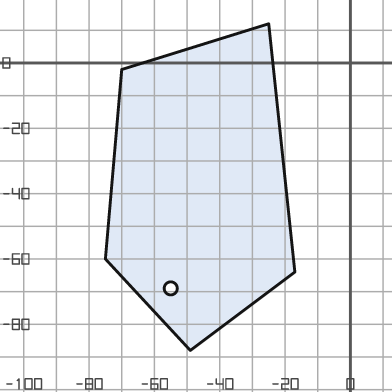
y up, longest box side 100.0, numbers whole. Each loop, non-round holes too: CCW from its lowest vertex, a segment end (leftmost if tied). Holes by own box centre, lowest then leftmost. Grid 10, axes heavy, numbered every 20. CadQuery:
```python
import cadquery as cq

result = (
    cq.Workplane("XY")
    .moveTo(-49.0, -88.0)
    .lineTo(-17.0, -64.0)
    .lineTo(-25.0, 12.0)
    .lineTo(-70.0, -2.0)
    .lineTo(-75.0, -60.0)
    .close()
    .moveTo(-55.0, -69.0)
    .circle(2.0)
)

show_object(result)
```